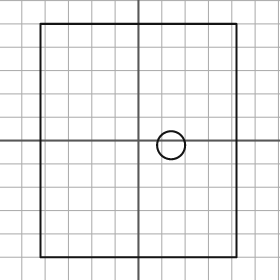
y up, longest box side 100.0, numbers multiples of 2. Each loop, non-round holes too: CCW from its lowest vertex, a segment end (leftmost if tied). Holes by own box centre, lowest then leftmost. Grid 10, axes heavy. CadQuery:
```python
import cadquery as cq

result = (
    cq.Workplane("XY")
    .moveTo(-42.0, -50.0)
    .lineTo(42.0, -50.0)
    .lineTo(42.0, 50.0)
    .lineTo(-42.0, 50.0)
    .close()
    .moveTo(14.0, -2.0)
    .circle(6.0)
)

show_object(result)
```